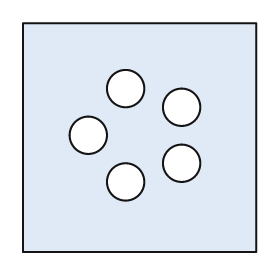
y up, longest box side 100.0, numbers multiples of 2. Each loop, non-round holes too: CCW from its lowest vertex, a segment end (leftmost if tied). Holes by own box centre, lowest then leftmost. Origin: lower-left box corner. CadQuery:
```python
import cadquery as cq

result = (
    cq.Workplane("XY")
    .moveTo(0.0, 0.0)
    .lineTo(100.0, 0.0)
    .lineTo(100.0, 98.0)
    .lineTo(0.0, 98.0)
    .close()
    .moveTo(44.0, 30.0)
    .circle(8.0)
    .moveTo(68.0, 38.0)
    .circle(8.0)
    .moveTo(28.0, 50.0)
    .circle(8.0)
    .moveTo(68.0, 62.0)
    .circle(8.0)
    .moveTo(44.0, 70.0)
    .circle(8.0)
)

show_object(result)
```